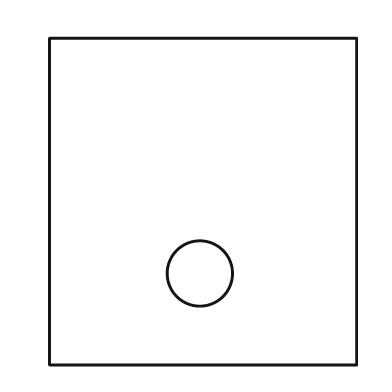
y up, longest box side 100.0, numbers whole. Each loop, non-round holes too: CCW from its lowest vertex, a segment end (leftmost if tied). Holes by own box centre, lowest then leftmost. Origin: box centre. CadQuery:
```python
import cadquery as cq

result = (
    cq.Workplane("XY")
    .moveTo(-47.0, -50.0)
    .lineTo(47.0, -50.0)
    .lineTo(47.0, 50.0)
    .lineTo(-47.0, 50.0)
    .close()
    .moveTo(-1.0, -22.0)
    .circle(10.0)
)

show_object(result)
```